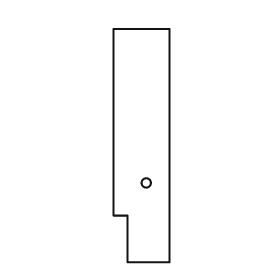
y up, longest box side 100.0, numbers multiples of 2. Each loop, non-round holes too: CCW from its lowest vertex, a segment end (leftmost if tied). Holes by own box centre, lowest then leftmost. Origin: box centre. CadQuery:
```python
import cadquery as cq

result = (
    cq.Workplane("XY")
    .moveTo(-6.0, -50.0)
    .lineTo(12.0, -50.0)
    .lineTo(12.0, 50.0)
    .lineTo(-12.0, 50.0)
    .lineTo(-12.0, -30.0)
    .lineTo(-6.0, -30.0)
    .close()
    .moveTo(2.0, -16.0)
    .circle(2.0)
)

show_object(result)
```